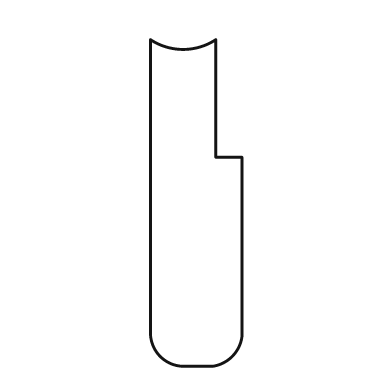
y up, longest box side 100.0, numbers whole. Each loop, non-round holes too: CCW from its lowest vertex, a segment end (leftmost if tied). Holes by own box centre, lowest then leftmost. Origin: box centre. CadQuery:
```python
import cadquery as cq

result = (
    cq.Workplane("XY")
    .moveTo(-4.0, -50.0)
    .lineTo(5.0, -50.0)
    .threePointArc((11.0, -47.0), (14.0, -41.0))
    .lineTo(14.0, 14.0)
    .lineTo(6.0, 14.0)
    .lineTo(6.0, 50.0)
    .threePointArc((-4.0, 47.0), (-14.0, 50.0))
    .lineTo(-14.0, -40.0)
    .threePointArc((-11.0, -47.0), (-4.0, -50.0))
    .close()
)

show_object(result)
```